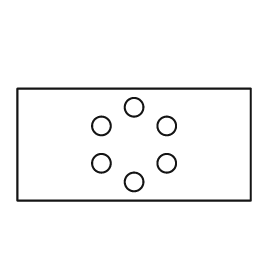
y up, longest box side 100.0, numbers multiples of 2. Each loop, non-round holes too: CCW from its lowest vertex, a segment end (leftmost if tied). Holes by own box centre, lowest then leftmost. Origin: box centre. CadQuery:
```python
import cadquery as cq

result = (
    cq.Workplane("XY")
    .moveTo(-50.0, -24.0)
    .lineTo(50.0, -24.0)
    .lineTo(50.0, 24.0)
    .lineTo(-50.0, 24.0)
    .close()
    .moveTo(0.0, -16.0)
    .circle(4.0)
    .moveTo(-14.0, -8.0)
    .circle(4.0)
    .moveTo(14.0, -8.0)
    .circle(4.0)
    .moveTo(-14.0, 8.0)
    .circle(4.0)
    .moveTo(14.0, 8.0)
    .circle(4.0)
    .moveTo(0.0, 16.0)
    .circle(4.0)
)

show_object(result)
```